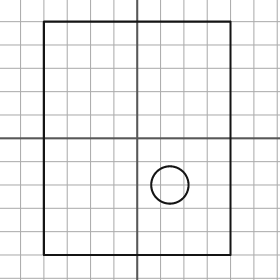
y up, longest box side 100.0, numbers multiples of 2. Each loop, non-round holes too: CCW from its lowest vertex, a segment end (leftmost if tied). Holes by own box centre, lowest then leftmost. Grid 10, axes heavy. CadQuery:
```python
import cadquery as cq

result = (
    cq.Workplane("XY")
    .moveTo(-40.0, -50.0)
    .lineTo(40.0, -50.0)
    .lineTo(40.0, 50.0)
    .lineTo(-40.0, 50.0)
    .close()
    .moveTo(14.0, -20.0)
    .circle(8.0)
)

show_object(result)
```